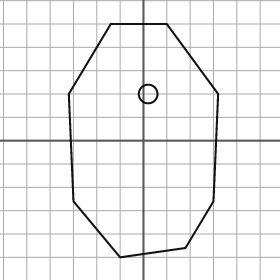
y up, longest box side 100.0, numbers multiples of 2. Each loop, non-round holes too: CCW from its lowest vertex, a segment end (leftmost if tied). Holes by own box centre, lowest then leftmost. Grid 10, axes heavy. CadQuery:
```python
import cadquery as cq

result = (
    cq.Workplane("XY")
    .moveTo(-10.0, -50.0)
    .lineTo(18.0, -46.0)
    .lineTo(30.0, -26.0)
    .lineTo(32.0, 20.0)
    .lineTo(10.0, 50.0)
    .lineTo(-14.0, 50.0)
    .lineTo(-32.0, 20.0)
    .lineTo(-30.0, -26.0)
    .close()
    .moveTo(2.0, 20.0)
    .circle(4.0)
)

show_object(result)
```